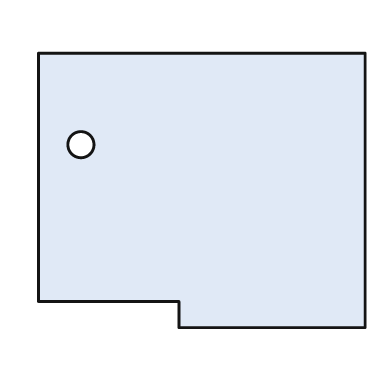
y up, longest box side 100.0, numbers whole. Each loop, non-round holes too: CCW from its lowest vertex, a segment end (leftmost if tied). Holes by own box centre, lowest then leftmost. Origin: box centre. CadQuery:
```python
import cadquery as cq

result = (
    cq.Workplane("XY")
    .moveTo(-7.0, -42.0)
    .lineTo(50.0, -42.0)
    .lineTo(50.0, 42.0)
    .lineTo(-50.0, 42.0)
    .lineTo(-50.0, -34.0)
    .lineTo(-7.0, -34.0)
    .close()
    .moveTo(-37.0, 14.0)
    .circle(4.0)
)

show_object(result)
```